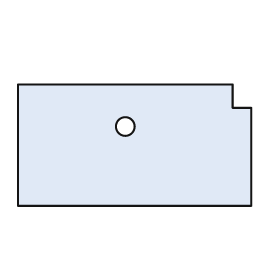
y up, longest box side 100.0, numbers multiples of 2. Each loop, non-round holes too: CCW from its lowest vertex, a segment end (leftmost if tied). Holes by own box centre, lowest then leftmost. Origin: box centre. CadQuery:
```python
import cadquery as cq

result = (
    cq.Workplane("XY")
    .moveTo(-50.0, -26.0)
    .lineTo(50.0, -26.0)
    .lineTo(50.0, 16.0)
    .lineTo(42.0, 16.0)
    .lineTo(42.0, 26.0)
    .lineTo(-50.0, 26.0)
    .close()
    .moveTo(-4.0, 8.0)
    .circle(4.0)
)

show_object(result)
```